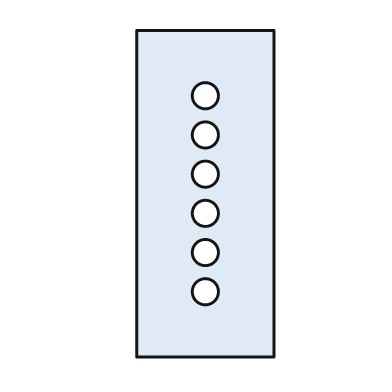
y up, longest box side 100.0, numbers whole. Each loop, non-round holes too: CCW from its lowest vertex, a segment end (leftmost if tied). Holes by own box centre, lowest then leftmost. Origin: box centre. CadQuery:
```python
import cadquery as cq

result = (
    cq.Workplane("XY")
    .moveTo(-21.0, -50.0)
    .lineTo(21.0, -50.0)
    .lineTo(21.0, 50.0)
    .lineTo(-21.0, 50.0)
    .close()
    .moveTo(0.0, -30.0)
    .circle(4.0)
    .moveTo(0.0, -18.0)
    .circle(4.0)
    .moveTo(0.0, -6.0)
    .circle(4.0)
    .moveTo(0.0, 6.0)
    .circle(4.0)
    .moveTo(0.0, 18.0)
    .circle(4.0)
    .moveTo(0.0, 30.0)
    .circle(4.0)
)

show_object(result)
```